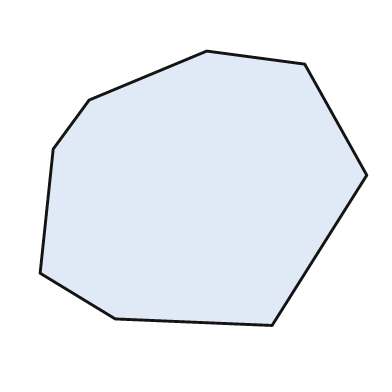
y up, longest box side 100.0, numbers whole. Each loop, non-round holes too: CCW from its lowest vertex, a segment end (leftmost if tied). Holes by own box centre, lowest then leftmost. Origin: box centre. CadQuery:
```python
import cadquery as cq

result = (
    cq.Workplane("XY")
    .moveTo(21.0, -42.0)
    .lineTo(50.0, 4.0)
    .lineTo(31.0, 38.0)
    .lineTo(1.0, 42.0)
    .lineTo(-35.0, 27.0)
    .lineTo(-46.0, 12.0)
    .lineTo(-50.0, -26.0)
    .lineTo(-27.0, -40.0)
    .close()
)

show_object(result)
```